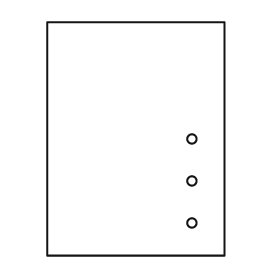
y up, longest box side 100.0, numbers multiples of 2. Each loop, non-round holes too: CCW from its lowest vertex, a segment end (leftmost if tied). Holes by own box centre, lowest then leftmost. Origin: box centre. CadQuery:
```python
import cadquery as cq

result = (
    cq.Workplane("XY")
    .moveTo(-38.0, -50.0)
    .lineTo(38.0, -50.0)
    .lineTo(38.0, 50.0)
    .lineTo(-38.0, 50.0)
    .close()
    .moveTo(24.0, -36.0)
    .circle(2.0)
    .moveTo(24.0, -18.0)
    .circle(2.0)
    .moveTo(24.0, 0.0)
    .circle(2.0)
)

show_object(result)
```